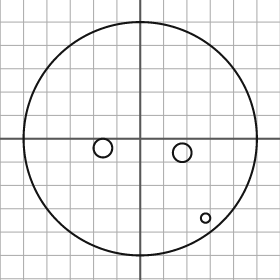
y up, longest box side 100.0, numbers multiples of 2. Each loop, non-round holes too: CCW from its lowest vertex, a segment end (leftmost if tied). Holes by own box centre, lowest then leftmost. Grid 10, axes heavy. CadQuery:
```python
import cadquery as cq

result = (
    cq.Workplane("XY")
    .moveTo(0.0, 0.0)
    .circle(50.0)
    .moveTo(28.0, -34.0)
    .circle(2.0)
    .moveTo(18.0, -6.0)
    .circle(4.0)
    .moveTo(-16.0, -4.0)
    .circle(4.0)
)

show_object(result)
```